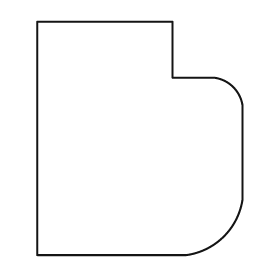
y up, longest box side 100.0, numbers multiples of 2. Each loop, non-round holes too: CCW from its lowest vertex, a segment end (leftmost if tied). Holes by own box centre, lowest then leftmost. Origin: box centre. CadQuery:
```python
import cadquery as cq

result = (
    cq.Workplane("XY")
    .moveTo(-44.0, -50.0)
    .lineTo(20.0, -50.0)
    .threePointArc((36.0, -42.0), (44.0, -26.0))
    .lineTo(44.0, 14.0)
    .threePointArc((40.0, 22.0), (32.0, 26.0))
    .lineTo(14.0, 26.0)
    .lineTo(14.0, 50.0)
    .lineTo(-44.0, 50.0)
    .close()
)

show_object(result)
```